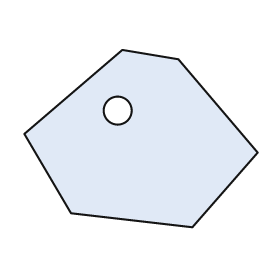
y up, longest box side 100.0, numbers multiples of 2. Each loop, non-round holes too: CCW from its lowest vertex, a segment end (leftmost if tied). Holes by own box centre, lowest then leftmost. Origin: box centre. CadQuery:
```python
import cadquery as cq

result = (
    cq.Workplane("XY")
    .moveTo(22.0, -38.0)
    .lineTo(50.0, -6.0)
    .lineTo(16.0, 34.0)
    .lineTo(-8.0, 38.0)
    .lineTo(-50.0, 2.0)
    .lineTo(-30.0, -32.0)
    .close()
    .moveTo(-10.0, 12.0)
    .circle(6.0)
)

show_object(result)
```